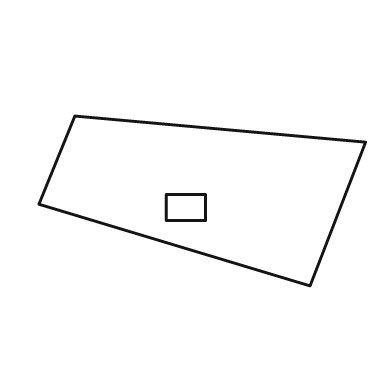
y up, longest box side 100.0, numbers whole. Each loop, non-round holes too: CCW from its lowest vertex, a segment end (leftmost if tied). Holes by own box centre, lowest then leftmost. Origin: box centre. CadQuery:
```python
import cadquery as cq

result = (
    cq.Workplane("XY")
    .moveTo(33.0, -26.0)
    .lineTo(50.0, 18.0)
    .lineTo(-39.0, 26.0)
    .lineTo(-50.0, -1.0)
    .close()
    .moveTo(-11.0, -6.0)
    .lineTo(1.0, -6.0)
    .lineTo(1.0, 2.0)
    .lineTo(-11.0, 2.0)
    .close()
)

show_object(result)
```